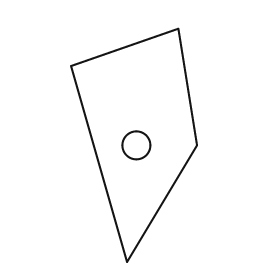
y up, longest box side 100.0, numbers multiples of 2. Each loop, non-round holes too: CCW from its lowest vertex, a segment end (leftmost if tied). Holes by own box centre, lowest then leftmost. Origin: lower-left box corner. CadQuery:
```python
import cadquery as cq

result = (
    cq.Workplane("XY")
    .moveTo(24.0, 0.0)
    .lineTo(54.0, 50.0)
    .lineTo(46.0, 100.0)
    .lineTo(0.0, 84.0)
    .close()
    .moveTo(28.0, 50.0)
    .circle(6.0)
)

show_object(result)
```